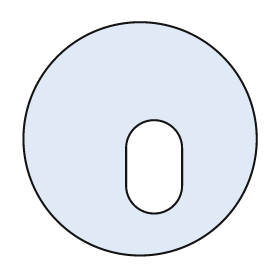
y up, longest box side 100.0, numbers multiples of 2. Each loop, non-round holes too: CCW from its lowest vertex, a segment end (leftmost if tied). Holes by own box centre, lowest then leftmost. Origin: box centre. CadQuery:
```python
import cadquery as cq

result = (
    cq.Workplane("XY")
    .moveTo(0.0, 0.0)
    .circle(50.0)
    .moveTo(-6.0, -20.0)
    .threePointArc((6.0, -32.0), (18.0, -20.0))
    .lineTo(18.0, -4.0)
    .threePointArc((6.0, 8.0), (-6.0, -4.0))
    .close()
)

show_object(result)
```